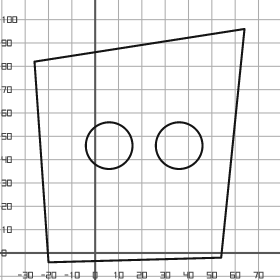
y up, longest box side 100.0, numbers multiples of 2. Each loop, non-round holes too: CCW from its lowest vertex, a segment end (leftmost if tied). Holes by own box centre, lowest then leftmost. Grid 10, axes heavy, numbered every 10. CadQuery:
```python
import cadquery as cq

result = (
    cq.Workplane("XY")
    .moveTo(-20.0, -4.0)
    .lineTo(54.0, -2.0)
    .lineTo(64.0, 96.0)
    .lineTo(-26.0, 82.0)
    .close()
    .moveTo(6.0, 46.0)
    .circle(10.0)
    .moveTo(36.0, 46.0)
    .circle(10.0)
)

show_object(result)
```